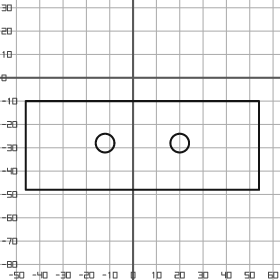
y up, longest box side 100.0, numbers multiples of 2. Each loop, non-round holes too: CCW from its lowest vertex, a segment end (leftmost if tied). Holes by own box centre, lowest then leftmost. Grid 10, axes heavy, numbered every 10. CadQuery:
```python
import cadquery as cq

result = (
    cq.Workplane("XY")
    .moveTo(-46.0, -48.0)
    .lineTo(54.0, -48.0)
    .lineTo(54.0, -10.0)
    .lineTo(-46.0, -10.0)
    .close()
    .moveTo(-12.0, -28.0)
    .circle(4.0)
    .moveTo(20.0, -28.0)
    .circle(4.0)
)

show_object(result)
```